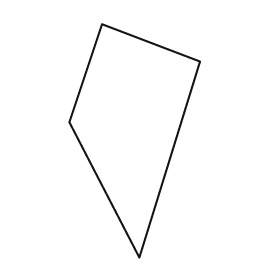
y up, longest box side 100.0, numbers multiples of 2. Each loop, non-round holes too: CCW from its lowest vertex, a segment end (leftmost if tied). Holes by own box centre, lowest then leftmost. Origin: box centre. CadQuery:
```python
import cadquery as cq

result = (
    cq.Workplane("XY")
    .moveTo(2.0, -50.0)
    .lineTo(28.0, 34.0)
    .lineTo(-14.0, 50.0)
    .lineTo(-28.0, 8.0)
    .close()
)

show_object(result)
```